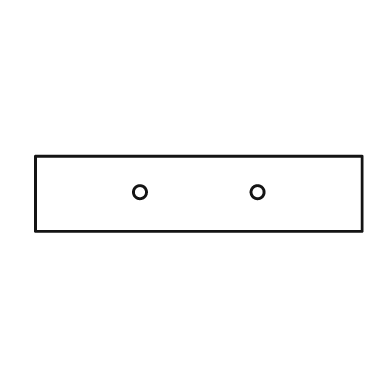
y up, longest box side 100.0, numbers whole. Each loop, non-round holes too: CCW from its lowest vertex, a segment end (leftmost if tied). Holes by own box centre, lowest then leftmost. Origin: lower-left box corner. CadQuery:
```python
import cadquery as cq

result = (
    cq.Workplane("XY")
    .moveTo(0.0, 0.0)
    .lineTo(100.0, 0.0)
    .lineTo(100.0, 23.0)
    .lineTo(0.0, 23.0)
    .close()
    .moveTo(32.0, 12.0)
    .circle(2.0)
    .moveTo(68.0, 12.0)
    .circle(2.0)
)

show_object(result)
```